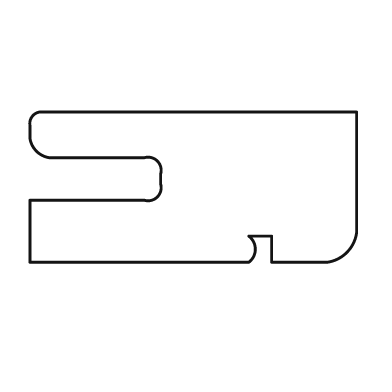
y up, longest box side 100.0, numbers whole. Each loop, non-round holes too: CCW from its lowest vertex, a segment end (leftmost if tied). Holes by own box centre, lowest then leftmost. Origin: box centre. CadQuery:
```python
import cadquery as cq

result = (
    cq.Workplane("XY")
    .moveTo(-50.0, -23.0)
    .lineTo(17.0, -23.0)
    .threePointArc((19.0, -19.0), (17.0, -15.0))
    .lineTo(24.0, -15.0)
    .lineTo(24.0, -23.0)
    .lineTo(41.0, -23.0)
    .threePointArc((47.0, -20.0), (50.0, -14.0))
    .lineTo(50.0, 23.0)
    .lineTo(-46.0, 23.0)
    .threePointArc((-49.0, 22.0), (-50.0, 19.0))
    .lineTo(-50.0, 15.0)
    .threePointArc((-48.0, 11.0), (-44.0, 9.0))
    .lineTo(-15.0, 9.0)
    .threePointArc((-11.0, 8.0), (-10.0, 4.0))
    .lineTo(-10.0, 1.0)
    .threePointArc((-11.0, -3.0), (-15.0, -4.0))
    .lineTo(-50.0, -4.0)
    .close()
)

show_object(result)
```